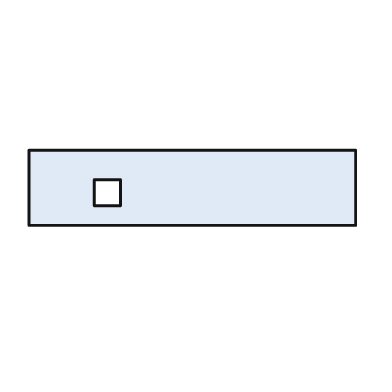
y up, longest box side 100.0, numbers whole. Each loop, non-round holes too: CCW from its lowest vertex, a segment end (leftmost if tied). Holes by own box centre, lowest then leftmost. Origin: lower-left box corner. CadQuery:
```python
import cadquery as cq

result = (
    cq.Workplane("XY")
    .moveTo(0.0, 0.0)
    .lineTo(100.0, 0.0)
    .lineTo(100.0, 23.0)
    .lineTo(0.0, 23.0)
    .close()
    .moveTo(20.0, 6.0)
    .lineTo(28.0, 6.0)
    .lineTo(28.0, 14.0)
    .lineTo(20.0, 14.0)
    .close()
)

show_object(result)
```